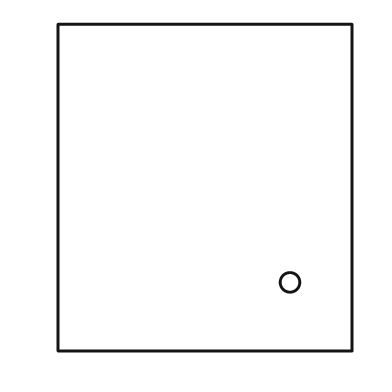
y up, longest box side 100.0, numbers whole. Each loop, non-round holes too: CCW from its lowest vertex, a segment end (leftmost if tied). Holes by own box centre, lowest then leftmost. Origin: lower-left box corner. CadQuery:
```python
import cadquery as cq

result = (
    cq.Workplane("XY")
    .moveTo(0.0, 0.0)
    .lineTo(90.0, 0.0)
    .lineTo(90.0, 100.0)
    .lineTo(0.0, 100.0)
    .close()
    .moveTo(71.0, 21.0)
    .circle(3.0)
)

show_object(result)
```